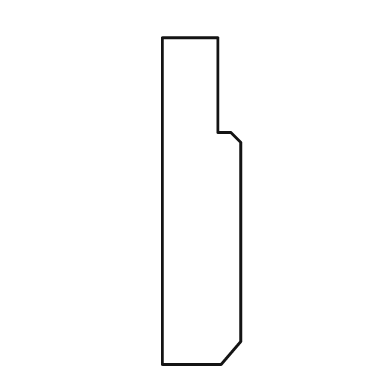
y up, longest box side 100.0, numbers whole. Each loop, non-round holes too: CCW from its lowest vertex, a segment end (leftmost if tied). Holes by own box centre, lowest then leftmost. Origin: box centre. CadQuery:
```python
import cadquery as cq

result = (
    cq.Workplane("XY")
    .moveTo(-12.0, -50.0)
    .lineTo(6.0, -50.0)
    .lineTo(12.0, -43.0)
    .lineTo(12.0, 18.0)
    .lineTo(9.0, 21.0)
    .lineTo(5.0, 21.0)
    .lineTo(5.0, 50.0)
    .lineTo(-12.0, 50.0)
    .close()
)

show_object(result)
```